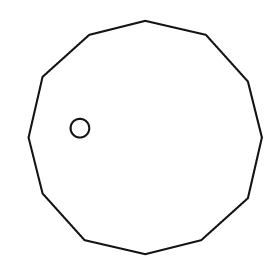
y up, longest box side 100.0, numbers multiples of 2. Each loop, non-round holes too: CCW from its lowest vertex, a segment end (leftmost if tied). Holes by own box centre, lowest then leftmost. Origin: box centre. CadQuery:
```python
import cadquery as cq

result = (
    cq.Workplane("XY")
    .moveTo(0.0, -50.0)
    .lineTo(24.0, -44.0)
    .lineTo(44.0, -26.0)
    .lineTo(50.0, 0.0)
    .lineTo(44.0, 24.0)
    .lineTo(26.0, 44.0)
    .lineTo(0.0, 50.0)
    .lineTo(-24.0, 44.0)
    .lineTo(-44.0, 26.0)
    .lineTo(-50.0, 0.0)
    .lineTo(-44.0, -24.0)
    .lineTo(-26.0, -44.0)
    .close()
    .moveTo(-28.0, 4.0)
    .circle(4.0)
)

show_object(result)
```